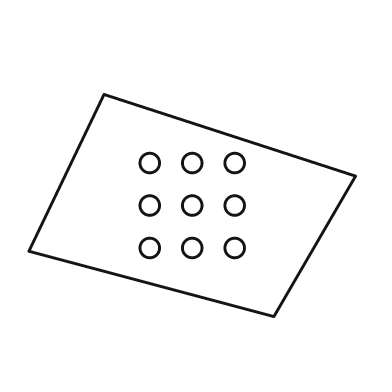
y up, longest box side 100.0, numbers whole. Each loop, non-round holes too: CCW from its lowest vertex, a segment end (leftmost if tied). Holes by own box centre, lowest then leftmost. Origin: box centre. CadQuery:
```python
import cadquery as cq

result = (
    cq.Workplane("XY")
    .moveTo(25.0, -34.0)
    .lineTo(50.0, 9.0)
    .lineTo(-27.0, 34.0)
    .lineTo(-50.0, -14.0)
    .close()
    .moveTo(-13.0, -13.0)
    .circle(3.0)
    .moveTo(0.0, -13.0)
    .circle(3.0)
    .moveTo(13.0, -13.0)
    .circle(3.0)
    .moveTo(-13.0, 0.0)
    .circle(3.0)
    .moveTo(0.0, 0.0)
    .circle(3.0)
    .moveTo(13.0, 0.0)
    .circle(3.0)
    .moveTo(-13.0, 13.0)
    .circle(3.0)
    .moveTo(0.0, 13.0)
    .circle(3.0)
    .moveTo(13.0, 13.0)
    .circle(3.0)
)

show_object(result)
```